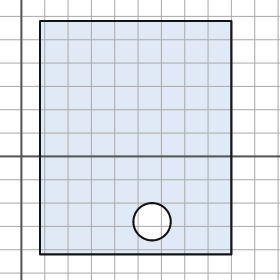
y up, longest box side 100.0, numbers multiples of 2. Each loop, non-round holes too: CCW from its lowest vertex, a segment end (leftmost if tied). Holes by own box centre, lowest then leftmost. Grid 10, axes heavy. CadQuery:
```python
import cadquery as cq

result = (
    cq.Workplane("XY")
    .moveTo(8.0, -42.0)
    .lineTo(90.0, -42.0)
    .lineTo(90.0, 58.0)
    .lineTo(8.0, 58.0)
    .close()
    .moveTo(56.0, -28.0)
    .circle(8.0)
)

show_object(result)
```